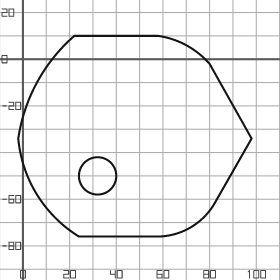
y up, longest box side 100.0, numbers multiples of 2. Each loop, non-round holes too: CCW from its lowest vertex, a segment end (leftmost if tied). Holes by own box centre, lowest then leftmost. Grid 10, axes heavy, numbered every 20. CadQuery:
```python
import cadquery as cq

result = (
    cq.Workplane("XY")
    .moveTo(24.0, -76.0)
    .lineTo(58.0, -76.0)
    .threePointArc((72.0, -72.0), (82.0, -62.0))
    .lineTo(98.0, -34.0)
    .lineTo(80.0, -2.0)
    .threePointArc((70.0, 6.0), (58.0, 10.0))
    .lineTo(22.0, 10.0)
    .threePointArc((6.0, -10.0), (-2.0, -34.0))
    .threePointArc((6.0, -58.0), (24.0, -76.0))
    .close()
    .moveTo(32.0, -50.0)
    .circle(8.0)
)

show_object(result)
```